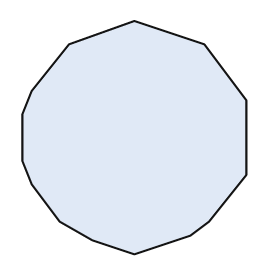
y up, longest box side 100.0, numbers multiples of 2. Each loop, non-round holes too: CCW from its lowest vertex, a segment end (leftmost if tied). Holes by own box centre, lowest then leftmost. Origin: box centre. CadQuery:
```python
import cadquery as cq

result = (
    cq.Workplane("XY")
    .moveTo(0.0, -50.0)
    .lineTo(24.0, -42.0)
    .lineTo(32.0, -36.0)
    .lineTo(48.0, -16.0)
    .lineTo(48.0, 16.0)
    .lineTo(30.0, 40.0)
    .lineTo(0.0, 50.0)
    .lineTo(-28.0, 40.0)
    .lineTo(-44.0, 20.0)
    .lineTo(-48.0, 10.0)
    .lineTo(-48.0, -10.0)
    .lineTo(-44.0, -20.0)
    .lineTo(-32.0, -36.0)
    .lineTo(-18.0, -44.0)
    .close()
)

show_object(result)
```